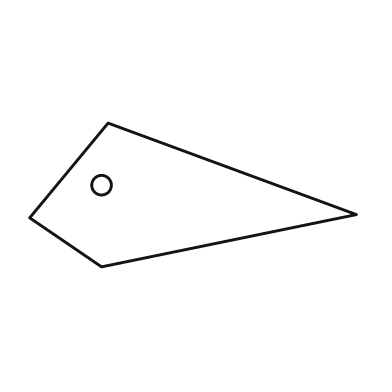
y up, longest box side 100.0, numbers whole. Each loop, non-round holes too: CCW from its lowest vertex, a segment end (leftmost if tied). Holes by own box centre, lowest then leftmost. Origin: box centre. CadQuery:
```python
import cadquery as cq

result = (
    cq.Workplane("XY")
    .moveTo(-28.0, -22.0)
    .lineTo(50.0, -6.0)
    .lineTo(-26.0, 22.0)
    .lineTo(-50.0, -7.0)
    .close()
    .moveTo(-28.0, 3.0)
    .circle(3.0)
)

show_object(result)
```